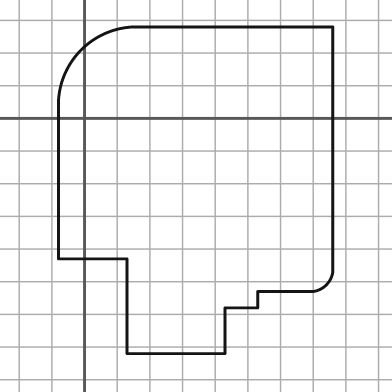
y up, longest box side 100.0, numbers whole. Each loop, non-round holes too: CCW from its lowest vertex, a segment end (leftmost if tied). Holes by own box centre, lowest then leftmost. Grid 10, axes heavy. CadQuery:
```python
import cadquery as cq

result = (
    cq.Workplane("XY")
    .moveTo(13.0, -72.0)
    .lineTo(43.0, -72.0)
    .lineTo(43.0, -58.0)
    .lineTo(53.0, -58.0)
    .lineTo(53.0, -53.0)
    .lineTo(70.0, -53.0)
    .threePointArc((74.0, -51.0), (76.0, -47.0))
    .lineTo(76.0, 28.0)
    .lineTo(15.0, 28.0)
    .threePointArc((-1.0, 21.0), (-8.0, 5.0))
    .lineTo(-8.0, -43.0)
    .lineTo(13.0, -43.0)
    .close()
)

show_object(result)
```